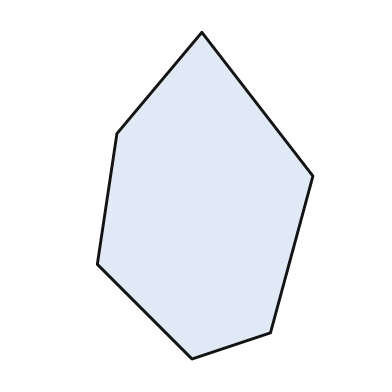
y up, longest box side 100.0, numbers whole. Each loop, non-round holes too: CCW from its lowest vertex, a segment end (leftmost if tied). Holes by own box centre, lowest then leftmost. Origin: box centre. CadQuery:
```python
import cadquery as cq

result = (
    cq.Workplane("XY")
    .moveTo(-4.0, -50.0)
    .lineTo(20.0, -42.0)
    .lineTo(33.0, 6.0)
    .lineTo(-1.0, 50.0)
    .lineTo(-27.0, 19.0)
    .lineTo(-33.0, -21.0)
    .close()
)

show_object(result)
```